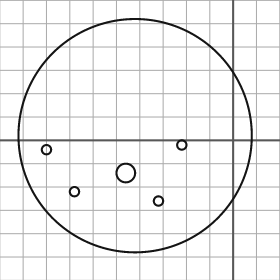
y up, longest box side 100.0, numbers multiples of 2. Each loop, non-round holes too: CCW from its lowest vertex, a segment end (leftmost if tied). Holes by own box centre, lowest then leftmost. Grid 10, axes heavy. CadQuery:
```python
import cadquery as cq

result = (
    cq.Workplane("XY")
    .moveTo(-42.0, 2.0)
    .circle(50.0)
    .moveTo(-32.0, -26.0)
    .circle(2.0)
    .moveTo(-68.0, -22.0)
    .circle(2.0)
    .moveTo(-46.0, -14.0)
    .circle(4.0)
    .moveTo(-80.0, -4.0)
    .circle(2.0)
    .moveTo(-22.0, -2.0)
    .circle(2.0)
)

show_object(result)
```